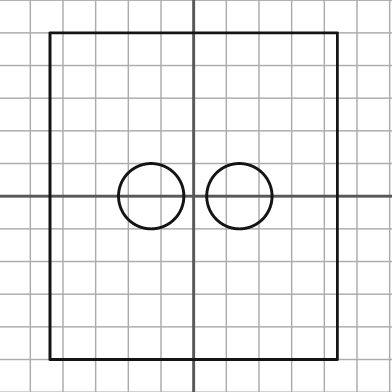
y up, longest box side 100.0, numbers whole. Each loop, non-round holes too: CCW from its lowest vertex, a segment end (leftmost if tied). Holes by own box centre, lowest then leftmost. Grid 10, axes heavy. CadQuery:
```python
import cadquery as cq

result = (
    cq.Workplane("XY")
    .moveTo(-44.0, -50.0)
    .lineTo(44.0, -50.0)
    .lineTo(44.0, 50.0)
    .lineTo(-44.0, 50.0)
    .close()
    .moveTo(-13.0, 0.0)
    .circle(10.0)
    .moveTo(14.0, 0.0)
    .circle(10.0)
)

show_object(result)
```